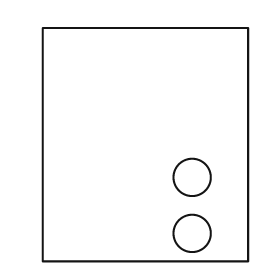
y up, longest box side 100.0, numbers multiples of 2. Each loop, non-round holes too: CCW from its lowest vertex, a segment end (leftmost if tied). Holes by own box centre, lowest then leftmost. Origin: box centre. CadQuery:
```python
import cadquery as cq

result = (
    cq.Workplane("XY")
    .moveTo(-44.0, -50.0)
    .lineTo(44.0, -50.0)
    .lineTo(44.0, 50.0)
    .lineTo(-44.0, 50.0)
    .close()
    .moveTo(20.0, -38.0)
    .circle(8.0)
    .moveTo(20.0, -14.0)
    .circle(8.0)
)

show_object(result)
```